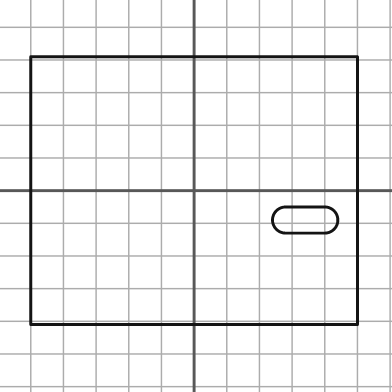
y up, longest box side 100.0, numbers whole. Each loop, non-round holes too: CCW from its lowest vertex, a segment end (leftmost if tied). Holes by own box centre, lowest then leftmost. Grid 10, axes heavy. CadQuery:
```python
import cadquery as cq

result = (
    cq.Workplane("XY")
    .moveTo(-50.0, -41.0)
    .lineTo(50.0, -41.0)
    .lineTo(50.0, 41.0)
    .lineTo(-50.0, 41.0)
    .close()
    .moveTo(28.0, -13.0)
    .lineTo(40.0, -13.0)
    .threePointArc((44.0, -9.0), (40.0, -5.0))
    .lineTo(28.0, -5.0)
    .threePointArc((24.0, -9.0), (28.0, -13.0))
    .close()
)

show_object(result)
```